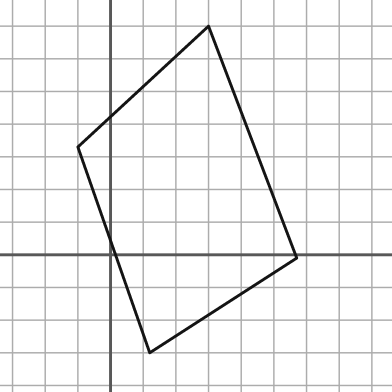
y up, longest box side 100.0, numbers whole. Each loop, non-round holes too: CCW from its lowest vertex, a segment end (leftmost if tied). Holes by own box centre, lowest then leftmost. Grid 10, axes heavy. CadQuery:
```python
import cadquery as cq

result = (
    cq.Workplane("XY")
    .moveTo(12.0, -30.0)
    .lineTo(57.0, -1.0)
    .lineTo(30.0, 70.0)
    .lineTo(-10.0, 33.0)
    .close()
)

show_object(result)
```